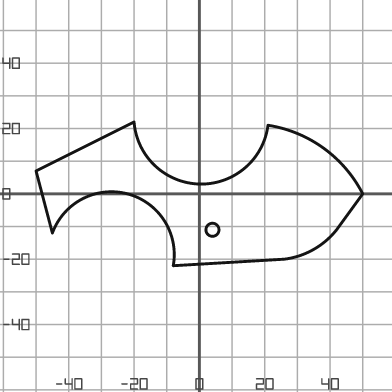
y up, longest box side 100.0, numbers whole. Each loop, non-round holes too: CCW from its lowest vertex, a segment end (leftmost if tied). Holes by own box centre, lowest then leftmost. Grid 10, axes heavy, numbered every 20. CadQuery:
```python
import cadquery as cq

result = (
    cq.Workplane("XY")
    .moveTo(-8.0, -22.0)
    .lineTo(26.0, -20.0)
    .threePointArc((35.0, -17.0), (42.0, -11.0))
    .lineTo(50.0, 0.0)
    .threePointArc((38.0, 14.0), (21.0, 21.0))
    .threePointArc((0.0, 3.0), (-20.0, 22.0))
    .lineTo(-50.0, 7.0)
    .lineTo(-45.0, -12.0)
    .threePointArc((-22.0, 0.0), (-8.0, -22.0))
    .close()
    .moveTo(4.0, -11.0)
    .circle(2.0)
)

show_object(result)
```